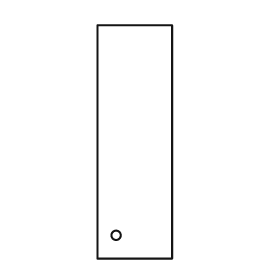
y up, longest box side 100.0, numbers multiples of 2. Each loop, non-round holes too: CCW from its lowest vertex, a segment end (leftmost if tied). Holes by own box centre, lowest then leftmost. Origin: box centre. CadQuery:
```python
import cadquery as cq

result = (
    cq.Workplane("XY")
    .moveTo(-16.0, -50.0)
    .lineTo(16.0, -50.0)
    .lineTo(16.0, 50.0)
    .lineTo(-16.0, 50.0)
    .close()
    .moveTo(-8.0, -40.0)
    .circle(2.0)
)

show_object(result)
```